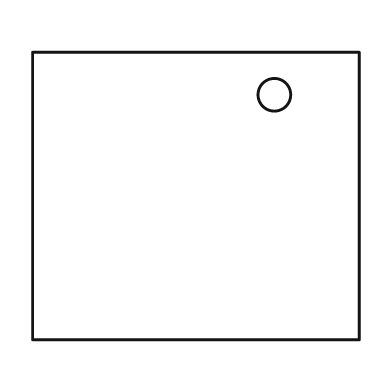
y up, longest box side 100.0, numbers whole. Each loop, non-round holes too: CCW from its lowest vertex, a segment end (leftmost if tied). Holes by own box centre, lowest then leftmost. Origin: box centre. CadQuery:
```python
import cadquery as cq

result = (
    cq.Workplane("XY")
    .moveTo(-50.0, -44.0)
    .lineTo(50.0, -44.0)
    .lineTo(50.0, 44.0)
    .lineTo(-50.0, 44.0)
    .close()
    .moveTo(24.0, 31.0)
    .circle(5.0)
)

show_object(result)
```